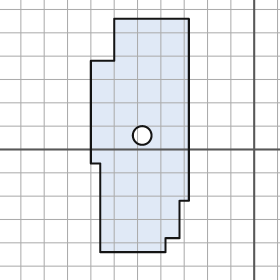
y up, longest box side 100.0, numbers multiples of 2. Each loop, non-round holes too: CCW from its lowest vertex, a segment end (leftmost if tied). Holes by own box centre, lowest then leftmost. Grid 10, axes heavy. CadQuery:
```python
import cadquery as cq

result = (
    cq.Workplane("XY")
    .moveTo(-66.0, -44.0)
    .lineTo(-38.0, -44.0)
    .lineTo(-38.0, -38.0)
    .lineTo(-32.0, -38.0)
    .lineTo(-32.0, -22.0)
    .lineTo(-28.0, -22.0)
    .lineTo(-28.0, 56.0)
    .lineTo(-60.0, 56.0)
    .lineTo(-60.0, 38.0)
    .lineTo(-70.0, 38.0)
    .lineTo(-70.0, -6.0)
    .lineTo(-66.0, -6.0)
    .close()
    .moveTo(-48.0, 6.0)
    .circle(4.0)
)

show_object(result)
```